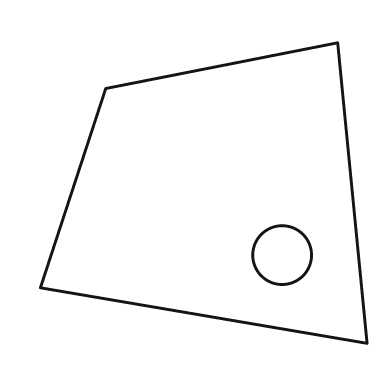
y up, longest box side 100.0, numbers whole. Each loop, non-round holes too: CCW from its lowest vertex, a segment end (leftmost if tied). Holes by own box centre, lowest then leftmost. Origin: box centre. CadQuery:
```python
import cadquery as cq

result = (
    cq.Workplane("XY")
    .moveTo(50.0, -46.0)
    .lineTo(41.0, 46.0)
    .lineTo(-30.0, 32.0)
    .lineTo(-50.0, -29.0)
    .close()
    .moveTo(24.0, -19.0)
    .circle(9.0)
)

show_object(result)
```